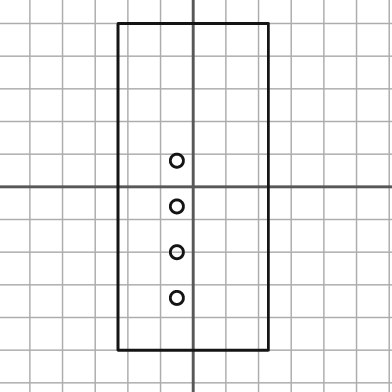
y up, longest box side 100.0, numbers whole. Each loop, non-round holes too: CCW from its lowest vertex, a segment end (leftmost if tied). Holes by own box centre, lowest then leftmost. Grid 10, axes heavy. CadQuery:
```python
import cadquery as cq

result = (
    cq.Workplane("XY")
    .moveTo(-23.0, -50.0)
    .lineTo(23.0, -50.0)
    .lineTo(23.0, 50.0)
    .lineTo(-23.0, 50.0)
    .close()
    .moveTo(-5.0, -34.0)
    .circle(2.0)
    .moveTo(-5.0, -20.0)
    .circle(2.0)
    .moveTo(-5.0, -6.0)
    .circle(2.0)
    .moveTo(-5.0, 8.0)
    .circle(2.0)
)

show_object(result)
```